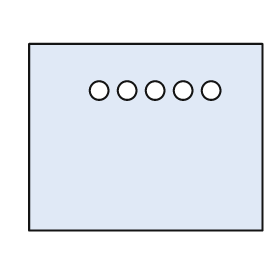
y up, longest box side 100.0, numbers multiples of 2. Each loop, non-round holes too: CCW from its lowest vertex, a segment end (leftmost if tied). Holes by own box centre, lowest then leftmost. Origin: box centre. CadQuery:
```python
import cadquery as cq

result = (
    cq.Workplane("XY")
    .moveTo(-50.0, -40.0)
    .lineTo(50.0, -40.0)
    .lineTo(50.0, 40.0)
    .lineTo(-50.0, 40.0)
    .close()
    .moveTo(-20.0, 20.0)
    .circle(4.0)
    .moveTo(-8.0, 20.0)
    .circle(4.0)
    .moveTo(4.0, 20.0)
    .circle(4.0)
    .moveTo(16.0, 20.0)
    .circle(4.0)
    .moveTo(28.0, 20.0)
    .circle(4.0)
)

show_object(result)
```